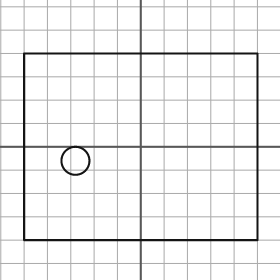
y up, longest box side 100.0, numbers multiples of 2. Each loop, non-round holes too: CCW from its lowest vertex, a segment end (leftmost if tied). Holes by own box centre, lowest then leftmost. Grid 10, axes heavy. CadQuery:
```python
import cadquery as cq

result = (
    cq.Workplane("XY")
    .moveTo(-50.0, -40.0)
    .lineTo(50.0, -40.0)
    .lineTo(50.0, 40.0)
    .lineTo(-50.0, 40.0)
    .close()
    .moveTo(-28.0, -6.0)
    .circle(6.0)
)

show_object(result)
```